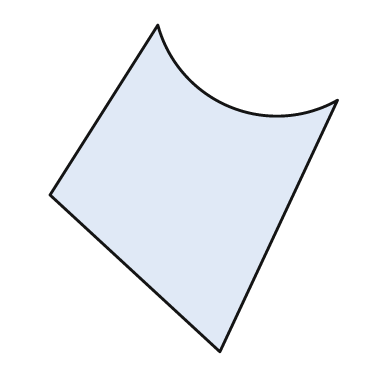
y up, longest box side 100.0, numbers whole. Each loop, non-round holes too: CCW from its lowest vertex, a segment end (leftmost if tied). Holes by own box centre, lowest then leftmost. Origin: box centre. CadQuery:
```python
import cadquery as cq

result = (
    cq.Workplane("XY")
    .moveTo(8.0, -50.0)
    .lineTo(44.0, 27.0)
    .threePointArc((11.0, 25.0), (-11.0, 50.0))
    .lineTo(-44.0, -2.0)
    .close()
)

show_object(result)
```